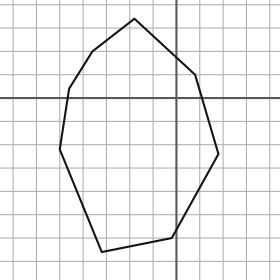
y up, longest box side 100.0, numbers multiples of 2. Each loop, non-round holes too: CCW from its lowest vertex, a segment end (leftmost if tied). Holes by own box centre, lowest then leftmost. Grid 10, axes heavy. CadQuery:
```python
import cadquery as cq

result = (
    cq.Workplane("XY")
    .moveTo(-32.0, -66.0)
    .lineTo(-2.0, -60.0)
    .lineTo(18.0, -24.0)
    .lineTo(8.0, 10.0)
    .lineTo(-18.0, 34.0)
    .lineTo(-36.0, 20.0)
    .lineTo(-46.0, 4.0)
    .lineTo(-50.0, -22.0)
    .close()
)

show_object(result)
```